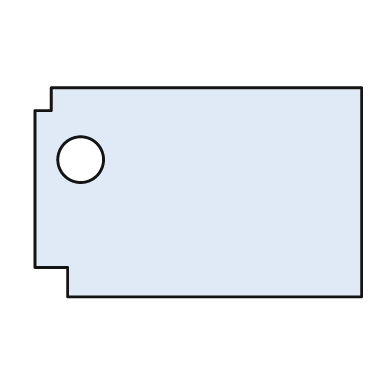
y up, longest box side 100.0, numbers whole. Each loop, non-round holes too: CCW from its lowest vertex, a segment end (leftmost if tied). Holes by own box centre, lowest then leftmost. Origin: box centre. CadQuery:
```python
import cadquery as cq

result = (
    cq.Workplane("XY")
    .moveTo(-40.0, -32.0)
    .lineTo(50.0, -32.0)
    .lineTo(50.0, 32.0)
    .lineTo(-45.0, 32.0)
    .lineTo(-45.0, 25.0)
    .lineTo(-50.0, 25.0)
    .lineTo(-50.0, -23.0)
    .lineTo(-40.0, -23.0)
    .close()
    .moveTo(-36.0, 10.0)
    .circle(7.0)
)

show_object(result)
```